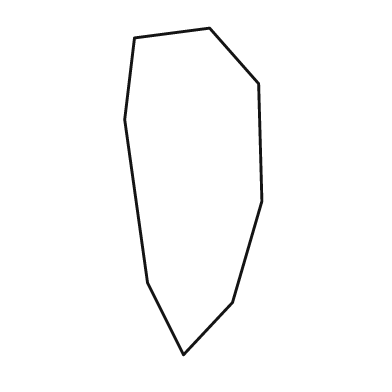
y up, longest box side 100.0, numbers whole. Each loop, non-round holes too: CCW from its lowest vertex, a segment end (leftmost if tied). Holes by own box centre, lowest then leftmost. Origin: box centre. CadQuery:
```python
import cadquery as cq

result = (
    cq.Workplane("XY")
    .moveTo(-3.0, -50.0)
    .lineTo(12.0, -34.0)
    .lineTo(21.0, -3.0)
    .lineTo(20.0, 33.0)
    .lineTo(5.0, 50.0)
    .lineTo(-18.0, 47.0)
    .lineTo(-21.0, 22.0)
    .lineTo(-14.0, -28.0)
    .close()
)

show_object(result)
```